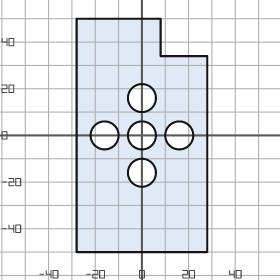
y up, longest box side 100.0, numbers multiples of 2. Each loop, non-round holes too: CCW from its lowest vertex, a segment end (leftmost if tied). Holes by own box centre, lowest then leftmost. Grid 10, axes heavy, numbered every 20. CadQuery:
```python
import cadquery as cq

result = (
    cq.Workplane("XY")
    .moveTo(-28.0, -50.0)
    .lineTo(28.0, -50.0)
    .lineTo(28.0, 34.0)
    .lineTo(8.0, 34.0)
    .lineTo(8.0, 50.0)
    .lineTo(-28.0, 50.0)
    .close()
    .moveTo(0.0, -16.0)
    .circle(6.0)
    .moveTo(-16.0, 0.0)
    .circle(6.0)
    .moveTo(0.0, 0.0)
    .circle(6.0)
    .moveTo(16.0, 0.0)
    .circle(6.0)
    .moveTo(0.0, 16.0)
    .circle(6.0)
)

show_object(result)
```